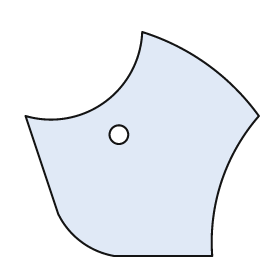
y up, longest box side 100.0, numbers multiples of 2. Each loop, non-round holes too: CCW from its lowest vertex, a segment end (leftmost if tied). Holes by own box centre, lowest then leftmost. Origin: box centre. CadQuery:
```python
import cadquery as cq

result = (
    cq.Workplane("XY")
    .moveTo(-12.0, -48.0)
    .lineTo(30.0, -48.0)
    .threePointArc((34.0, -16.0), (50.0, 12.0))
    .threePointArc((28.0, 34.0), (0.0, 48.0))
    .threePointArc((-16.0, 18.0), (-50.0, 12.0))
    .lineTo(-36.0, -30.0)
    .threePointArc((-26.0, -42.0), (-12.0, -48.0))
    .close()
    .moveTo(-10.0, 4.0)
    .circle(4.0)
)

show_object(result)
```